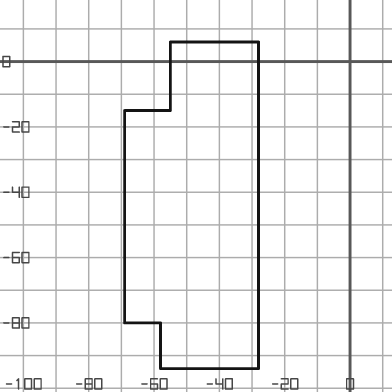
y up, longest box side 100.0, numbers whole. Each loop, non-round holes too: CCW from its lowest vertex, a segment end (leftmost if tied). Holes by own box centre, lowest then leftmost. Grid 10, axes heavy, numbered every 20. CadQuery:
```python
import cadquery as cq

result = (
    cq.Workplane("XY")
    .moveTo(-58.0, -94.0)
    .lineTo(-28.0, -94.0)
    .lineTo(-28.0, 6.0)
    .lineTo(-55.0, 6.0)
    .lineTo(-55.0, -15.0)
    .lineTo(-69.0, -15.0)
    .lineTo(-69.0, -80.0)
    .lineTo(-58.0, -80.0)
    .close()
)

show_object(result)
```